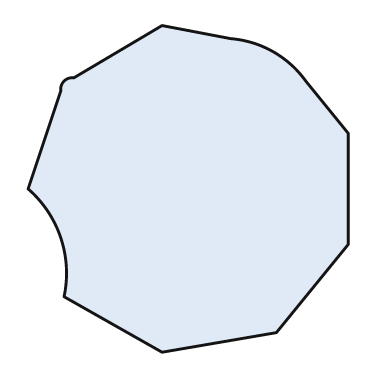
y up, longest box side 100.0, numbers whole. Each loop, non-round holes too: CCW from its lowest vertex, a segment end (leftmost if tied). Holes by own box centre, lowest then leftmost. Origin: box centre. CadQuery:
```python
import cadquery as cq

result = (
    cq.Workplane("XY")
    .moveTo(-8.0, -50.0)
    .lineTo(27.0, -44.0)
    .lineTo(49.0, -17.0)
    .lineTo(49.0, 17.0)
    .lineTo(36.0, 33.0)
    .threePointArc((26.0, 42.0), (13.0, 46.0))
    .lineTo(-8.0, 50.0)
    .lineTo(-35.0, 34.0)
    .threePointArc((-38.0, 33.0), (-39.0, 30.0))
    .lineTo(-49.0, 0.0)
    .threePointArc((-39.0, -15.0), (-38.0, -33.0))
    .close()
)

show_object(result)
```